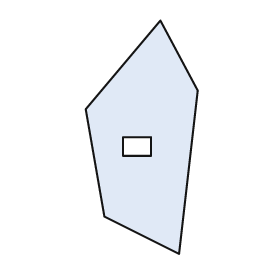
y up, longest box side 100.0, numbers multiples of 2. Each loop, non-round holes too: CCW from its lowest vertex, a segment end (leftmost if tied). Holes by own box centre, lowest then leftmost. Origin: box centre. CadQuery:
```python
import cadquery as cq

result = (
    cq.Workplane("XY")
    .moveTo(16.0, -50.0)
    .lineTo(24.0, 20.0)
    .lineTo(8.0, 50.0)
    .lineTo(-24.0, 12.0)
    .lineTo(-16.0, -34.0)
    .close()
    .moveTo(-8.0, -8.0)
    .lineTo(4.0, -8.0)
    .lineTo(4.0, 0.0)
    .lineTo(-8.0, 0.0)
    .close()
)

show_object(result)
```